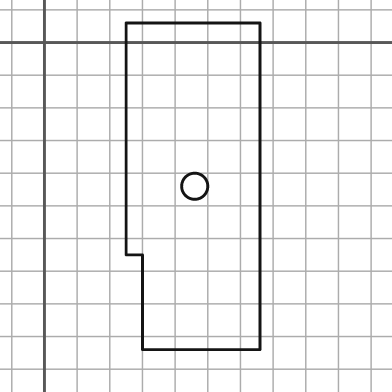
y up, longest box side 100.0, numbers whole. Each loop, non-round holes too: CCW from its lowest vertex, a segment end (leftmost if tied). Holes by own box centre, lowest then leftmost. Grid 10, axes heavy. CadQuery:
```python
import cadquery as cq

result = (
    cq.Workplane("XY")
    .moveTo(30.0, -94.0)
    .lineTo(66.0, -94.0)
    .lineTo(66.0, 6.0)
    .lineTo(25.0, 6.0)
    .lineTo(25.0, -65.0)
    .lineTo(30.0, -65.0)
    .close()
    .moveTo(46.0, -44.0)
    .circle(4.0)
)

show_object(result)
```